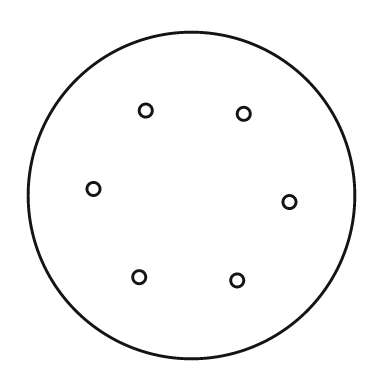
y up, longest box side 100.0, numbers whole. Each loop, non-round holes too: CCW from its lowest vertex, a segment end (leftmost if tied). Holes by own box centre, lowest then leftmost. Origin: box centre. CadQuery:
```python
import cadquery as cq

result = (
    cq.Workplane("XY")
    .moveTo(0.0, 0.0)
    .circle(50.0)
    .moveTo(14.0, -26.0)
    .circle(2.0)
    .moveTo(-16.0, -25.0)
    .circle(2.0)
    .moveTo(30.0, -2.0)
    .circle(2.0)
    .moveTo(-30.0, 2.0)
    .circle(2.0)
    .moveTo(16.0, 25.0)
    .circle(2.0)
    .moveTo(-14.0, 26.0)
    .circle(2.0)
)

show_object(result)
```